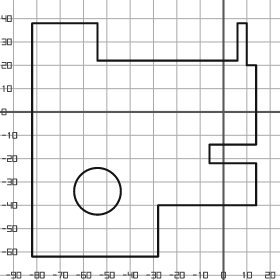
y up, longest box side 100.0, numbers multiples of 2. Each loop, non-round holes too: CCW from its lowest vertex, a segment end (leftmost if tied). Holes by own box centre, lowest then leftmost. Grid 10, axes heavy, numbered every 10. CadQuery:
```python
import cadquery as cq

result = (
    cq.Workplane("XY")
    .moveTo(-82.0, -62.0)
    .lineTo(-28.0, -62.0)
    .lineTo(-28.0, -40.0)
    .lineTo(14.0, -40.0)
    .lineTo(14.0, -22.0)
    .lineTo(-6.0, -22.0)
    .lineTo(-6.0, -14.0)
    .lineTo(14.0, -14.0)
    .lineTo(14.0, 20.0)
    .lineTo(10.0, 20.0)
    .lineTo(10.0, 38.0)
    .lineTo(6.0, 38.0)
    .lineTo(6.0, 22.0)
    .lineTo(-54.0, 22.0)
    .lineTo(-54.0, 38.0)
    .lineTo(-82.0, 38.0)
    .close()
    .moveTo(-54.0, -34.0)
    .circle(10.0)
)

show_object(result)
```